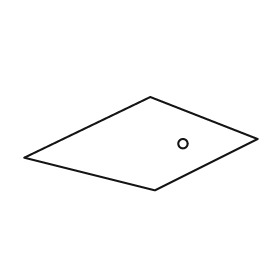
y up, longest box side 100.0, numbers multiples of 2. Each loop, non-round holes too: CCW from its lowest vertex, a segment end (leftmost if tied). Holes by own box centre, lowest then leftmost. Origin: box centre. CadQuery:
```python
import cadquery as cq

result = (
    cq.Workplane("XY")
    .moveTo(6.0, -20.0)
    .lineTo(50.0, 2.0)
    .lineTo(4.0, 20.0)
    .lineTo(-50.0, -6.0)
    .close()
    .moveTo(18.0, 0.0)
    .circle(2.0)
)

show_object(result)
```